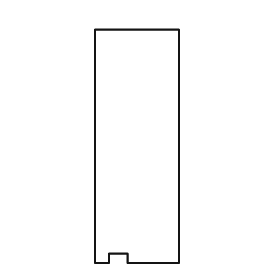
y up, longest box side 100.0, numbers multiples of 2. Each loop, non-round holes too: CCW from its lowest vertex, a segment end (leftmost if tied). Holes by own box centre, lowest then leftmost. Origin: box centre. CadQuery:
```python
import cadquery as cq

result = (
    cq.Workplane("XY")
    .moveTo(-18.0, -50.0)
    .lineTo(-12.0, -50.0)
    .lineTo(-12.0, -46.0)
    .lineTo(-4.0, -46.0)
    .lineTo(-4.0, -50.0)
    .lineTo(18.0, -50.0)
    .lineTo(18.0, 50.0)
    .lineTo(-18.0, 50.0)
    .close()
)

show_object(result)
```